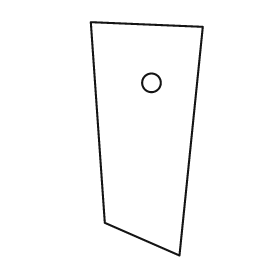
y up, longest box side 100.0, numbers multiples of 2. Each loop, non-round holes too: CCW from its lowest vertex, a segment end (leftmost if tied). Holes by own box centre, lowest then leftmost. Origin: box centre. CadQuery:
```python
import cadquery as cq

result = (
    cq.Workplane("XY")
    .moveTo(14.0, -50.0)
    .lineTo(24.0, 48.0)
    .lineTo(-24.0, 50.0)
    .lineTo(-18.0, -36.0)
    .close()
    .moveTo(2.0, 24.0)
    .circle(4.0)
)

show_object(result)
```